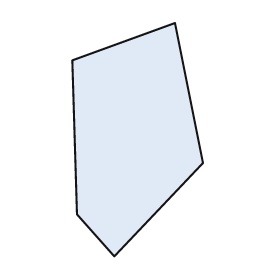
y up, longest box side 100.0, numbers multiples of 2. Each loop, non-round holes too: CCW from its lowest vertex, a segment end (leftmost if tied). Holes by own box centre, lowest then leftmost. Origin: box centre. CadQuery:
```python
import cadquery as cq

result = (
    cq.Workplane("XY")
    .moveTo(-10.0, -50.0)
    .lineTo(28.0, -10.0)
    .lineTo(16.0, 50.0)
    .lineTo(-28.0, 34.0)
    .lineTo(-26.0, -32.0)
    .close()
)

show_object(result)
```